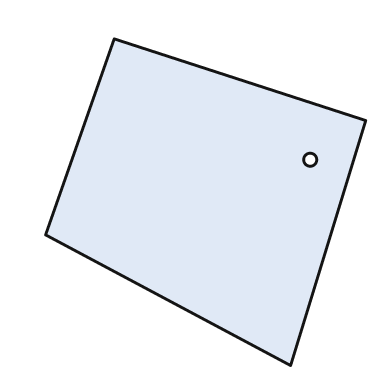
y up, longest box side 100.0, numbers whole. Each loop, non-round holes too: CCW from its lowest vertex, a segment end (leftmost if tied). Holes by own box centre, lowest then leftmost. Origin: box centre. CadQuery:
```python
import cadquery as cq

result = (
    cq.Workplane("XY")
    .moveTo(26.0, -50.0)
    .lineTo(49.0, 25.0)
    .lineTo(-28.0, 50.0)
    .lineTo(-49.0, -10.0)
    .close()
    .moveTo(32.0, 13.0)
    .circle(2.0)
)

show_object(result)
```